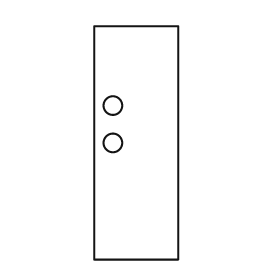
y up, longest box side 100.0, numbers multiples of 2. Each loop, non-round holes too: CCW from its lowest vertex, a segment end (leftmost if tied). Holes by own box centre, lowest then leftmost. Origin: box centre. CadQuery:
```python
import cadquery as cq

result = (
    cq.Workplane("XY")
    .moveTo(-18.0, -50.0)
    .lineTo(18.0, -50.0)
    .lineTo(18.0, 50.0)
    .lineTo(-18.0, 50.0)
    .close()
    .moveTo(-10.0, 0.0)
    .circle(4.0)
    .moveTo(-10.0, 16.0)
    .circle(4.0)
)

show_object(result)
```